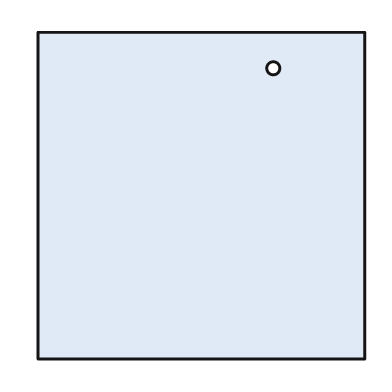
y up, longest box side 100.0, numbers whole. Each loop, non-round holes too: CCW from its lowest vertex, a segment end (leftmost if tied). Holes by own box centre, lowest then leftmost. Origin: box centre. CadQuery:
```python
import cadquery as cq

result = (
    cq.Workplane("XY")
    .moveTo(-50.0, -50.0)
    .lineTo(50.0, -50.0)
    .lineTo(50.0, 50.0)
    .lineTo(-50.0, 50.0)
    .close()
    .moveTo(22.0, 39.0)
    .circle(2.0)
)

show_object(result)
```